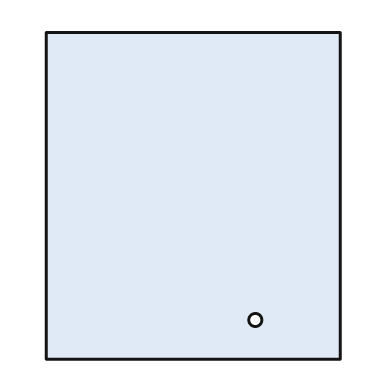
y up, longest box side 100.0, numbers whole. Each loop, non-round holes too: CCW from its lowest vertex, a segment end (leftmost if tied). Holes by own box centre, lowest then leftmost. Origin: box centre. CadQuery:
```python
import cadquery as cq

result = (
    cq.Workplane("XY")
    .moveTo(-45.0, -50.0)
    .lineTo(45.0, -50.0)
    .lineTo(45.0, 50.0)
    .lineTo(-45.0, 50.0)
    .close()
    .moveTo(19.0, -38.0)
    .circle(2.0)
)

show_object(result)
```